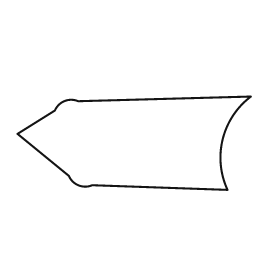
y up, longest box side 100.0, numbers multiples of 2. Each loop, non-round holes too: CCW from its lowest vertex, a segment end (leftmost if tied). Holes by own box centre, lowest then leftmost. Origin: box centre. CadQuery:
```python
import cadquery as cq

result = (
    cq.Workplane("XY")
    .moveTo(40.0, -20.0)
    .threePointArc((38.0, 2.0), (50.0, 20.0))
    .lineTo(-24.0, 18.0)
    .threePointArc((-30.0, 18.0), (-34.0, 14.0))
    .lineTo(-50.0, 4.0)
    .lineTo(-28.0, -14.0)
    .threePointArc((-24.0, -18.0), (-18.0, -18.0))
    .close()
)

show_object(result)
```